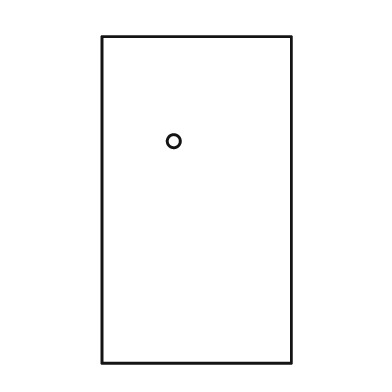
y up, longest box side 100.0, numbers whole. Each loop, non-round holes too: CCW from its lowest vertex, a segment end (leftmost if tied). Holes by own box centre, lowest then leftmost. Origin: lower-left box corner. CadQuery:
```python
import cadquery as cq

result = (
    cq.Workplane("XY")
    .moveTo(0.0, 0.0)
    .lineTo(58.0, 0.0)
    .lineTo(58.0, 100.0)
    .lineTo(0.0, 100.0)
    .close()
    .moveTo(22.0, 68.0)
    .circle(2.0)
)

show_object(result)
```